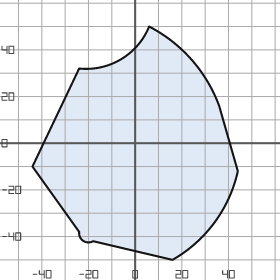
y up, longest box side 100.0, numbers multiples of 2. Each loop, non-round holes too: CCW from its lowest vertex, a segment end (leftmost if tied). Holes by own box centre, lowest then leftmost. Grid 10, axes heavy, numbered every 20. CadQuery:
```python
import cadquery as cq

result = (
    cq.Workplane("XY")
    .moveTo(16.0, -50.0)
    .threePointArc((34.0, -34.0), (44.0, -12.0))
    .lineTo(36.0, 16.0)
    .threePointArc((24.0, 36.0), (6.0, 50.0))
    .threePointArc((-6.0, 36.0), (-24.0, 32.0))
    .lineTo(-44.0, -10.0)
    .lineTo(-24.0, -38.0)
    .threePointArc((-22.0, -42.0), (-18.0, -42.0))
    .close()
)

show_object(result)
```